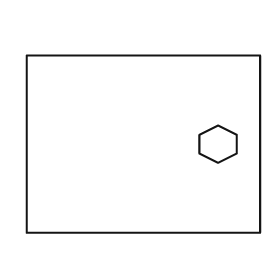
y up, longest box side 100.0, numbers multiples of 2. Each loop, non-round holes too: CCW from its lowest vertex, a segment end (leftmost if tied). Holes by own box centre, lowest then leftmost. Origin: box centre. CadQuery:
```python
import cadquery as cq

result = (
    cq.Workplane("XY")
    .moveTo(-50.0, -38.0)
    .lineTo(50.0, -38.0)
    .lineTo(50.0, 38.0)
    .lineTo(-50.0, 38.0)
    .close()
    .moveTo(32.0, -8.0)
    .lineTo(40.0, -4.0)
    .lineTo(40.0, 4.0)
    .lineTo(32.0, 8.0)
    .lineTo(24.0, 4.0)
    .lineTo(24.0, -4.0)
    .close()
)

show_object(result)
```